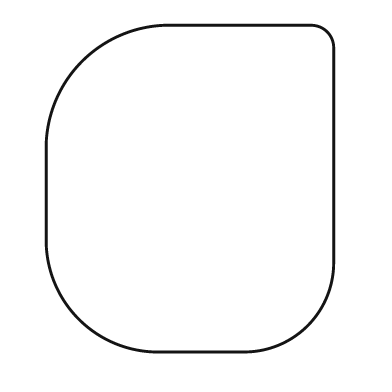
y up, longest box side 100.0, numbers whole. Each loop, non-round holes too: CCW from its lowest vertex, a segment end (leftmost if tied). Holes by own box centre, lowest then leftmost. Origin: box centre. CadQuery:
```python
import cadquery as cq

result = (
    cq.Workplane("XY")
    .moveTo(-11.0, -50.0)
    .lineTo(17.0, -50.0)
    .threePointArc((36.0, -42.0), (44.0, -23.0))
    .lineTo(44.0, 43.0)
    .threePointArc((42.0, 48.0), (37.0, 50.0))
    .lineTo(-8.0, 50.0)
    .threePointArc((-33.0, 39.0), (-44.0, 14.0))
    .lineTo(-44.0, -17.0)
    .threePointArc((-34.0, -40.0), (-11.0, -50.0))
    .close()
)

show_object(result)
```